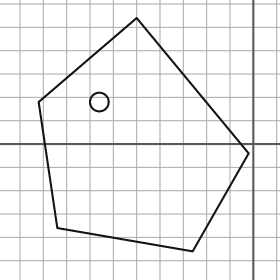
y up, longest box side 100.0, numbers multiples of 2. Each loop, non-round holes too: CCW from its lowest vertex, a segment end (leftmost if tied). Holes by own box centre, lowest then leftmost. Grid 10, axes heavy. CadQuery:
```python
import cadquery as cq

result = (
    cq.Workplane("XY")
    .moveTo(-26.0, -46.0)
    .lineTo(-2.0, -4.0)
    .lineTo(-50.0, 54.0)
    .lineTo(-92.0, 18.0)
    .lineTo(-84.0, -36.0)
    .close()
    .moveTo(-66.0, 18.0)
    .circle(4.0)
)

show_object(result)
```